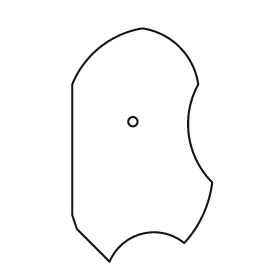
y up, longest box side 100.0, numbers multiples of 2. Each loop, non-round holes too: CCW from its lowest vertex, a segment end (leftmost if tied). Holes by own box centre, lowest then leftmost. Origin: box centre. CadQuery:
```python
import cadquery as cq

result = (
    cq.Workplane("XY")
    .moveTo(-14.0, -50.0)
    .threePointArc((0.0, -38.0), (18.0, -42.0))
    .threePointArc((26.0, -30.0), (30.0, -16.0))
    .threePointArc((20.0, 4.0), (24.0, 26.0))
    .threePointArc((16.0, 42.0), (0.0, 50.0))
    .threePointArc((-18.0, 42.0), (-30.0, 26.0))
    .lineTo(-30.0, -30.0)
    .lineTo(-28.0, -36.0)
    .close()
    .moveTo(-4.0, 10.0)
    .circle(2.0)
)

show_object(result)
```